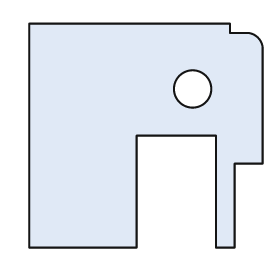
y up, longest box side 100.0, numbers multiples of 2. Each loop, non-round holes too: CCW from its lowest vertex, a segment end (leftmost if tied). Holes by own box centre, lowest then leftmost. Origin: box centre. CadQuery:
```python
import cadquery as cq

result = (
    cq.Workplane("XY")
    .moveTo(-50.0, -48.0)
    .lineTo(-4.0, -48.0)
    .lineTo(-4.0, 0.0)
    .lineTo(30.0, 0.0)
    .lineTo(30.0, -48.0)
    .lineTo(38.0, -48.0)
    .lineTo(38.0, -12.0)
    .lineTo(50.0, -12.0)
    .lineTo(50.0, 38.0)
    .threePointArc((48.0, 42.0), (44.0, 44.0))
    .lineTo(36.0, 44.0)
    .lineTo(36.0, 48.0)
    .lineTo(-50.0, 48.0)
    .close()
    .moveTo(20.0, 20.0)
    .circle(8.0)
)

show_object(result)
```